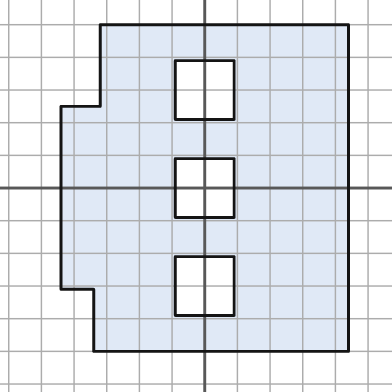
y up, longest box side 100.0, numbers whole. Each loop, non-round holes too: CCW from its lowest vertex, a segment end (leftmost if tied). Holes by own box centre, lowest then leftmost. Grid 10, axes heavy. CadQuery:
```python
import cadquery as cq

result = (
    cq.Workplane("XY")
    .moveTo(-34.0, -50.0)
    .lineTo(44.0, -50.0)
    .lineTo(44.0, 50.0)
    .lineTo(-32.0, 50.0)
    .lineTo(-32.0, 25.0)
    .lineTo(-44.0, 25.0)
    .lineTo(-44.0, -31.0)
    .lineTo(-34.0, -31.0)
    .close()
    .moveTo(-9.0, -39.0)
    .lineTo(9.0, -39.0)
    .lineTo(9.0, -21.0)
    .lineTo(-9.0, -21.0)
    .close()
    .moveTo(-9.0, -9.0)
    .lineTo(9.0, -9.0)
    .lineTo(9.0, 9.0)
    .lineTo(-9.0, 9.0)
    .close()
    .moveTo(-9.0, 21.0)
    .lineTo(9.0, 21.0)
    .lineTo(9.0, 39.0)
    .lineTo(-9.0, 39.0)
    .close()
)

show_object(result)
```